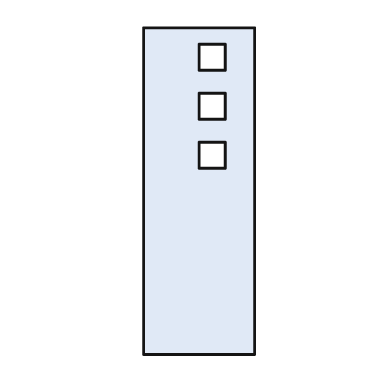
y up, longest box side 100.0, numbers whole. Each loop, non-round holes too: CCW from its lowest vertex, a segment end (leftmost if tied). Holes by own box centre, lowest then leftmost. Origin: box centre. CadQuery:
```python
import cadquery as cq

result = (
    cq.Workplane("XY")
    .moveTo(-17.0, -50.0)
    .lineTo(17.0, -50.0)
    .lineTo(17.0, 50.0)
    .lineTo(-17.0, 50.0)
    .close()
    .moveTo(0.0, 7.0)
    .lineTo(8.0, 7.0)
    .lineTo(8.0, 15.0)
    .lineTo(0.0, 15.0)
    .close()
    .moveTo(0.0, 22.0)
    .lineTo(8.0, 22.0)
    .lineTo(8.0, 30.0)
    .lineTo(0.0, 30.0)
    .close()
    .moveTo(0.0, 37.0)
    .lineTo(8.0, 37.0)
    .lineTo(8.0, 45.0)
    .lineTo(0.0, 45.0)
    .close()
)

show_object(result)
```